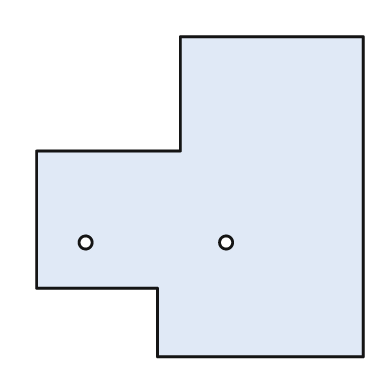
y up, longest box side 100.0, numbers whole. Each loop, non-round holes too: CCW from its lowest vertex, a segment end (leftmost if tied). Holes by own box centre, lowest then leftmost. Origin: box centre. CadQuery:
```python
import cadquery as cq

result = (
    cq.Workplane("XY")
    .moveTo(-13.0, -49.0)
    .lineTo(50.0, -49.0)
    .lineTo(50.0, 49.0)
    .lineTo(-6.0, 49.0)
    .lineTo(-6.0, 14.0)
    .lineTo(-50.0, 14.0)
    .lineTo(-50.0, -28.0)
    .lineTo(-13.0, -28.0)
    .close()
    .moveTo(-35.0, -14.0)
    .circle(2.0)
    .moveTo(8.0, -14.0)
    .circle(2.0)
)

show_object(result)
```